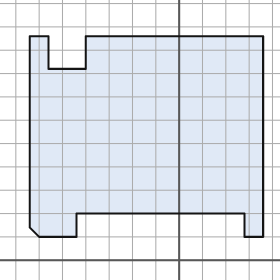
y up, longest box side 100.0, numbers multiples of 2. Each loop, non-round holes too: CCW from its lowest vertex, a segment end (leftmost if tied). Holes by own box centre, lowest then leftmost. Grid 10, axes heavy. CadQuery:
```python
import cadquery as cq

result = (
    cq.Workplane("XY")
    .moveTo(-60.0, 10.0)
    .lineTo(-44.0, 10.0)
    .lineTo(-44.0, 20.0)
    .lineTo(28.0, 20.0)
    .lineTo(28.0, 10.0)
    .lineTo(36.0, 10.0)
    .lineTo(36.0, 96.0)
    .lineTo(-40.0, 96.0)
    .lineTo(-40.0, 82.0)
    .lineTo(-56.0, 82.0)
    .lineTo(-56.0, 96.0)
    .lineTo(-64.0, 96.0)
    .lineTo(-64.0, 14.0)
    .close()
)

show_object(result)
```